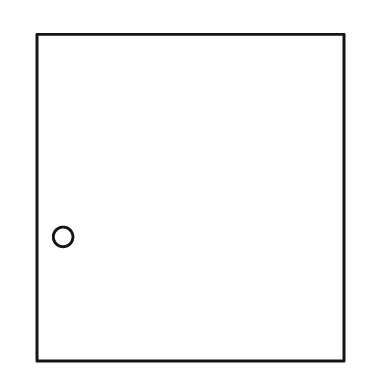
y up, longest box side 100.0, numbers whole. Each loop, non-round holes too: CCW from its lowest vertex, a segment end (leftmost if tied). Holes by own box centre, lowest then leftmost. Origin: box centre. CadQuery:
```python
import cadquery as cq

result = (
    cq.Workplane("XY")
    .moveTo(-47.0, -50.0)
    .lineTo(47.0, -50.0)
    .lineTo(47.0, 50.0)
    .lineTo(-47.0, 50.0)
    .close()
    .moveTo(-39.0, -12.0)
    .circle(3.0)
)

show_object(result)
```